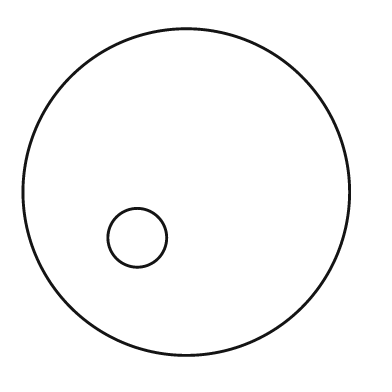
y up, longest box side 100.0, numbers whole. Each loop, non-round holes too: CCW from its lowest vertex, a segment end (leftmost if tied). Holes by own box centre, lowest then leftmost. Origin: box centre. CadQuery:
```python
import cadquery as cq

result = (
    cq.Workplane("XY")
    .moveTo(0.0, 0.0)
    .circle(50.0)
    .moveTo(-15.0, -14.0)
    .circle(9.0)
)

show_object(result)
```